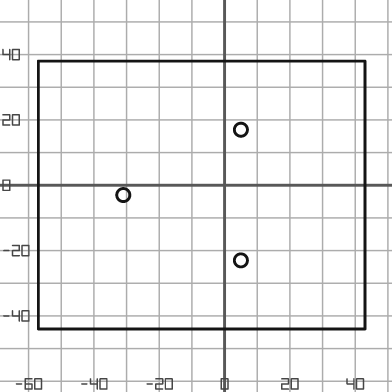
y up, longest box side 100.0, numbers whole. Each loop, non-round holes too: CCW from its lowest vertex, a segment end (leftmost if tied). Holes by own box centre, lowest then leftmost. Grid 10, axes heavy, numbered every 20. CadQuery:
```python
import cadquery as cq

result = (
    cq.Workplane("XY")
    .moveTo(-57.0, -44.0)
    .lineTo(43.0, -44.0)
    .lineTo(43.0, 38.0)
    .lineTo(-57.0, 38.0)
    .close()
    .moveTo(5.0, -23.0)
    .circle(2.0)
    .moveTo(-31.0, -3.0)
    .circle(2.0)
    .moveTo(5.0, 17.0)
    .circle(2.0)
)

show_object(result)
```